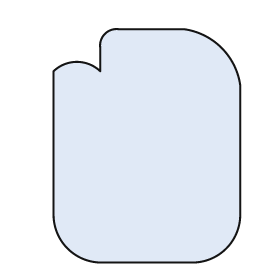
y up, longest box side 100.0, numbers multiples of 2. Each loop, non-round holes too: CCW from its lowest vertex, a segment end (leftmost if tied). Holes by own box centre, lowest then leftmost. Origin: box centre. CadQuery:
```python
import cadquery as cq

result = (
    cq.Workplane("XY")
    .moveTo(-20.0, -50.0)
    .lineTo(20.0, -50.0)
    .threePointArc((34.0, -44.0), (40.0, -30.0))
    .lineTo(40.0, 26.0)
    .threePointArc((32.0, 42.0), (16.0, 50.0))
    .lineTo(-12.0, 50.0)
    .threePointArc((-18.0, 48.0), (-20.0, 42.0))
    .lineTo(-20.0, 32.0)
    .threePointArc((-30.0, 36.0), (-40.0, 32.0))
    .lineTo(-40.0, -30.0)
    .threePointArc((-34.0, -44.0), (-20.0, -50.0))
    .close()
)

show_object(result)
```